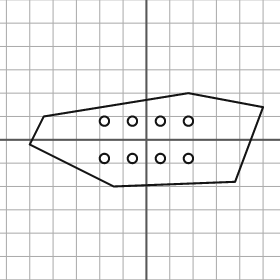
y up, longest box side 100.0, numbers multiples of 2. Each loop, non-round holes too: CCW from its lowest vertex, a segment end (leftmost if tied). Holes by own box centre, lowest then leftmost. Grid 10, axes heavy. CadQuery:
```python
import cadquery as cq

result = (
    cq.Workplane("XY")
    .moveTo(-14.0, -20.0)
    .lineTo(38.0, -18.0)
    .lineTo(50.0, 14.0)
    .lineTo(18.0, 20.0)
    .lineTo(-44.0, 10.0)
    .lineTo(-50.0, -2.0)
    .close()
    .moveTo(-18.0, -8.0)
    .circle(2.0)
    .moveTo(-6.0, -8.0)
    .circle(2.0)
    .moveTo(6.0, -8.0)
    .circle(2.0)
    .moveTo(18.0, -8.0)
    .circle(2.0)
    .moveTo(-18.0, 8.0)
    .circle(2.0)
    .moveTo(-6.0, 8.0)
    .circle(2.0)
    .moveTo(6.0, 8.0)
    .circle(2.0)
    .moveTo(18.0, 8.0)
    .circle(2.0)
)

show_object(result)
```